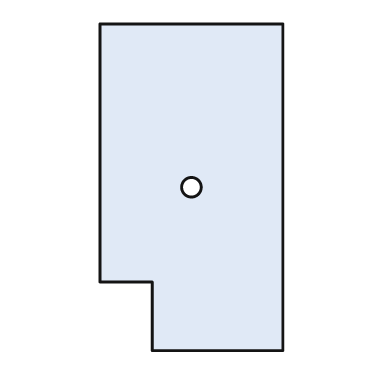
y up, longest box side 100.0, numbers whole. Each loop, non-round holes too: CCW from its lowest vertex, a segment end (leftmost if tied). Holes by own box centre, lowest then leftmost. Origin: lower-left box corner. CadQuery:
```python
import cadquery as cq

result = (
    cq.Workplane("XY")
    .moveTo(16.0, 0.0)
    .lineTo(56.0, 0.0)
    .lineTo(56.0, 100.0)
    .lineTo(0.0, 100.0)
    .lineTo(0.0, 21.0)
    .lineTo(16.0, 21.0)
    .close()
    .moveTo(28.0, 50.0)
    .circle(3.0)
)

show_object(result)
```